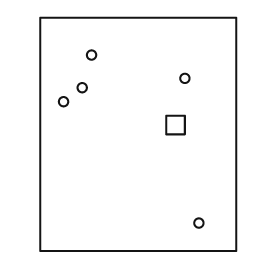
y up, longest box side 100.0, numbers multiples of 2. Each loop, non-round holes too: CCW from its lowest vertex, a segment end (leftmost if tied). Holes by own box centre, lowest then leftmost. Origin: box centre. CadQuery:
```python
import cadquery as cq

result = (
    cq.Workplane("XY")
    .moveTo(-42.0, -50.0)
    .lineTo(42.0, -50.0)
    .lineTo(42.0, 50.0)
    .lineTo(-42.0, 50.0)
    .close()
    .moveTo(26.0, -38.0)
    .circle(2.0)
    .moveTo(12.0, 0.0)
    .lineTo(20.0, 0.0)
    .lineTo(20.0, 8.0)
    .lineTo(12.0, 8.0)
    .close()
    .moveTo(-32.0, 14.0)
    .circle(2.0)
    .moveTo(-24.0, 20.0)
    .circle(2.0)
    .moveTo(20.0, 24.0)
    .circle(2.0)
    .moveTo(-20.0, 34.0)
    .circle(2.0)
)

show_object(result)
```